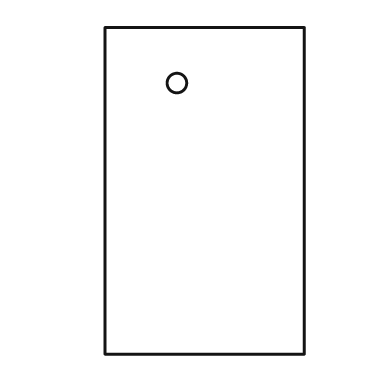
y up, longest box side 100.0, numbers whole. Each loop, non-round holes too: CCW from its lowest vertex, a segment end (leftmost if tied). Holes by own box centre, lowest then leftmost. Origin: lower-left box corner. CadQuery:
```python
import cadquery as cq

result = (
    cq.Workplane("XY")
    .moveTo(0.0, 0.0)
    .lineTo(61.0, 0.0)
    .lineTo(61.0, 100.0)
    .lineTo(0.0, 100.0)
    .close()
    .moveTo(22.0, 83.0)
    .circle(3.0)
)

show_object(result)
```